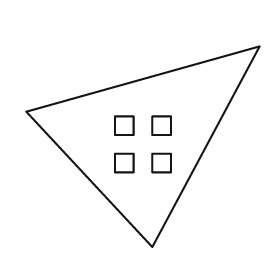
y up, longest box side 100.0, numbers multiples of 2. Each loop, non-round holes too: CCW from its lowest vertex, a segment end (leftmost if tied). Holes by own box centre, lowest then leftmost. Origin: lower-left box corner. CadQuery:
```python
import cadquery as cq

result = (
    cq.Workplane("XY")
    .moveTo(54.0, 0.0)
    .lineTo(100.0, 86.0)
    .lineTo(0.0, 58.0)
    .close()
    .moveTo(38.0, 32.0)
    .lineTo(46.0, 32.0)
    .lineTo(46.0, 40.0)
    .lineTo(38.0, 40.0)
    .close()
    .moveTo(54.0, 32.0)
    .lineTo(62.0, 32.0)
    .lineTo(62.0, 40.0)
    .lineTo(54.0, 40.0)
    .close()
    .moveTo(38.0, 48.0)
    .lineTo(46.0, 48.0)
    .lineTo(46.0, 56.0)
    .lineTo(38.0, 56.0)
    .close()
    .moveTo(54.0, 48.0)
    .lineTo(62.0, 48.0)
    .lineTo(62.0, 56.0)
    .lineTo(54.0, 56.0)
    .close()
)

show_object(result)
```